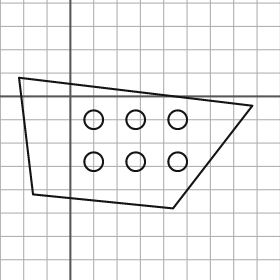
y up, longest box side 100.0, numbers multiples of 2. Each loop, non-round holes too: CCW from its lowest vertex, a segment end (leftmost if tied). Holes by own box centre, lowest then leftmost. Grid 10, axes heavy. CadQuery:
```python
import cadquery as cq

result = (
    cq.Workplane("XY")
    .moveTo(44.0, -48.0)
    .lineTo(78.0, -4.0)
    .lineTo(-22.0, 8.0)
    .lineTo(-16.0, -42.0)
    .close()
    .moveTo(10.0, -28.0)
    .circle(4.0)
    .moveTo(28.0, -28.0)
    .circle(4.0)
    .moveTo(46.0, -28.0)
    .circle(4.0)
    .moveTo(10.0, -10.0)
    .circle(4.0)
    .moveTo(28.0, -10.0)
    .circle(4.0)
    .moveTo(46.0, -10.0)
    .circle(4.0)
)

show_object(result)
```